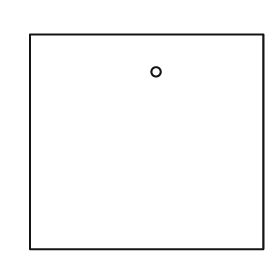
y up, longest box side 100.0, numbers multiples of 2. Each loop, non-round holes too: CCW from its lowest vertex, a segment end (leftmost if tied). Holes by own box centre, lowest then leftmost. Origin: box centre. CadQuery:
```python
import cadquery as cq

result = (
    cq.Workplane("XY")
    .moveTo(-50.0, -46.0)
    .lineTo(50.0, -46.0)
    .lineTo(50.0, 46.0)
    .lineTo(-50.0, 46.0)
    .close()
    .moveTo(4.0, 30.0)
    .circle(2.0)
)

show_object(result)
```